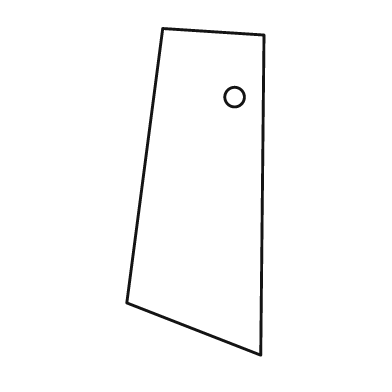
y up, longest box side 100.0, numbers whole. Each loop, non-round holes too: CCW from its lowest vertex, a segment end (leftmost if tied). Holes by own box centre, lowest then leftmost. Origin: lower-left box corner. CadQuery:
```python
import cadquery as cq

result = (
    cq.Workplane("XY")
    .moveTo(41.0, 0.0)
    .lineTo(42.0, 98.0)
    .lineTo(11.0, 100.0)
    .lineTo(0.0, 16.0)
    .close()
    .moveTo(33.0, 79.0)
    .circle(3.0)
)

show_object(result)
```